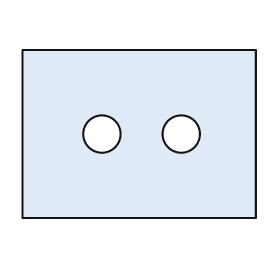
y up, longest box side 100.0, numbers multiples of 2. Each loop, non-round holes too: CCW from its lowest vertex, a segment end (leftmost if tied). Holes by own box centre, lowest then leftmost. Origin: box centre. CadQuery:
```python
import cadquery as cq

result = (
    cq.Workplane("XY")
    .moveTo(-50.0, -36.0)
    .lineTo(50.0, -36.0)
    .lineTo(50.0, 36.0)
    .lineTo(-50.0, 36.0)
    .close()
    .moveTo(-16.0, 0.0)
    .circle(8.0)
    .moveTo(18.0, 0.0)
    .circle(8.0)
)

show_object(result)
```